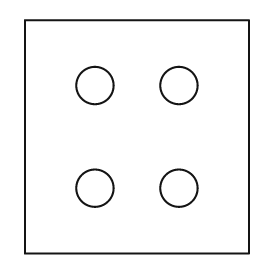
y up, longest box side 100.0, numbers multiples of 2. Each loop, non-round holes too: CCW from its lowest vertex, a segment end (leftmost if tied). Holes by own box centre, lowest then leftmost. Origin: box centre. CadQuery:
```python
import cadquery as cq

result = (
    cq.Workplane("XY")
    .moveTo(-48.0, -50.0)
    .lineTo(48.0, -50.0)
    .lineTo(48.0, 50.0)
    .lineTo(-48.0, 50.0)
    .close()
    .moveTo(-18.0, -22.0)
    .circle(8.0)
    .moveTo(18.0, -22.0)
    .circle(8.0)
    .moveTo(-18.0, 22.0)
    .circle(8.0)
    .moveTo(18.0, 22.0)
    .circle(8.0)
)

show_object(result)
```